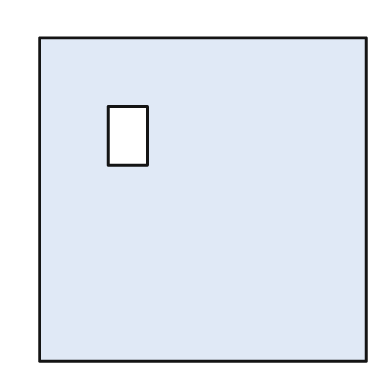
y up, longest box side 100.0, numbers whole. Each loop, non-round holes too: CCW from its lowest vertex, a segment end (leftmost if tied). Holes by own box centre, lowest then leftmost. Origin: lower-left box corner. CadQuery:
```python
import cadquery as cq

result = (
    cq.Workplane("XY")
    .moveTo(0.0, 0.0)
    .lineTo(100.0, 0.0)
    .lineTo(100.0, 99.0)
    .lineTo(0.0, 99.0)
    .close()
    .moveTo(21.0, 60.0)
    .lineTo(33.0, 60.0)
    .lineTo(33.0, 78.0)
    .lineTo(21.0, 78.0)
    .close()
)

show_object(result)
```